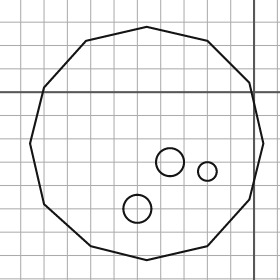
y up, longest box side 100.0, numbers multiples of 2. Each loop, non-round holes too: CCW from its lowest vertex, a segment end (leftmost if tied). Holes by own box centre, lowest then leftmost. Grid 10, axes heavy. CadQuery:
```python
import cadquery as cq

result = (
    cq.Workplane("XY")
    .moveTo(-46.0, -72.0)
    .lineTo(-20.0, -66.0)
    .lineTo(-2.0, -46.0)
    .lineTo(4.0, -22.0)
    .lineTo(-2.0, 4.0)
    .lineTo(-20.0, 22.0)
    .lineTo(-46.0, 28.0)
    .lineTo(-72.0, 22.0)
    .lineTo(-90.0, 2.0)
    .lineTo(-96.0, -22.0)
    .lineTo(-90.0, -48.0)
    .lineTo(-70.0, -66.0)
    .close()
    .moveTo(-50.0, -50.0)
    .circle(6.0)
    .moveTo(-20.0, -34.0)
    .circle(4.0)
    .moveTo(-36.0, -30.0)
    .circle(6.0)
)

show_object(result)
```